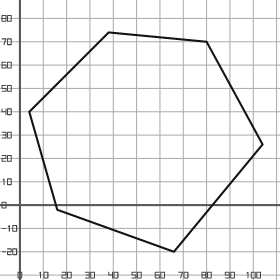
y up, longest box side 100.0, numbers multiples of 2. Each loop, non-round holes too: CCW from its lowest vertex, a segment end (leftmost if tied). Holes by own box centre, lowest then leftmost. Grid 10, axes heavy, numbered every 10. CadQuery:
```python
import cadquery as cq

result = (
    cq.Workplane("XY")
    .moveTo(66.0, -20.0)
    .lineTo(104.0, 26.0)
    .lineTo(80.0, 70.0)
    .lineTo(38.0, 74.0)
    .lineTo(4.0, 40.0)
    .lineTo(16.0, -2.0)
    .close()
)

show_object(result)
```